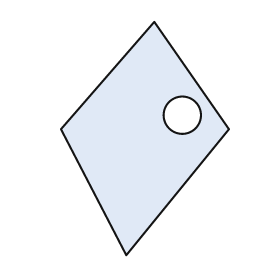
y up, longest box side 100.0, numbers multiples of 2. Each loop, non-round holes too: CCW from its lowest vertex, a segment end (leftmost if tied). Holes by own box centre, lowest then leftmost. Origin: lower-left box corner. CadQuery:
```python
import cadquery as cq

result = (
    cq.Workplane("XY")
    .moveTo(28.0, 0.0)
    .lineTo(72.0, 54.0)
    .lineTo(40.0, 100.0)
    .lineTo(0.0, 54.0)
    .close()
    .moveTo(52.0, 60.0)
    .circle(8.0)
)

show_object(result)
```